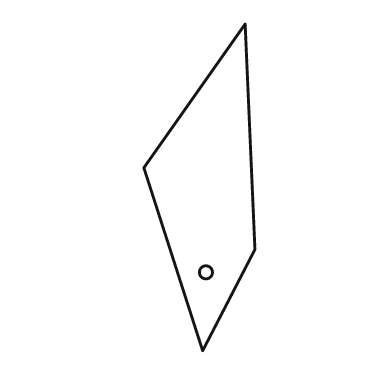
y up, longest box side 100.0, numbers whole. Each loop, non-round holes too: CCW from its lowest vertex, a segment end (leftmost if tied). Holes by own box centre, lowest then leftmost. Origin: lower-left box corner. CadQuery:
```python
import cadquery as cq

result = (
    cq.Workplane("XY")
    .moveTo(18.0, 0.0)
    .lineTo(34.0, 31.0)
    .lineTo(31.0, 100.0)
    .lineTo(0.0, 56.0)
    .close()
    .moveTo(19.0, 24.0)
    .circle(2.0)
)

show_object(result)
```